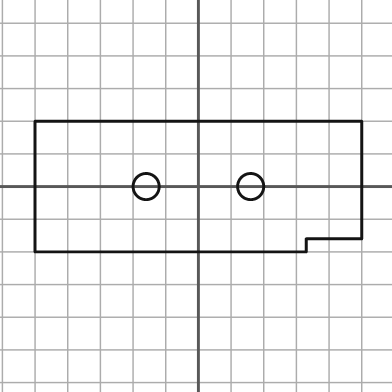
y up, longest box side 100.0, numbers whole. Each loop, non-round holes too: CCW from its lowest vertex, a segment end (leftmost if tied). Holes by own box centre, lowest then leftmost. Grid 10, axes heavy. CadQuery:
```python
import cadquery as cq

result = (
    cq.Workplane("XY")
    .moveTo(-50.0, -20.0)
    .lineTo(33.0, -20.0)
    .lineTo(33.0, -16.0)
    .lineTo(50.0, -16.0)
    .lineTo(50.0, 20.0)
    .lineTo(-50.0, 20.0)
    .close()
    .moveTo(-16.0, 0.0)
    .circle(4.0)
    .moveTo(16.0, 0.0)
    .circle(4.0)
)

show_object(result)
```